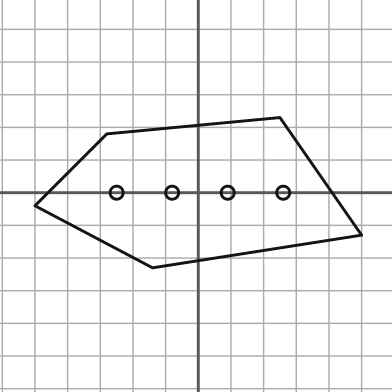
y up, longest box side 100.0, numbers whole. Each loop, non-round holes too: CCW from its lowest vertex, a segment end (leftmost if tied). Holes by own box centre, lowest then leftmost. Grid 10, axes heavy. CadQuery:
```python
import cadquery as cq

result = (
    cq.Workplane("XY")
    .moveTo(-14.0, -23.0)
    .lineTo(50.0, -13.0)
    .lineTo(25.0, 23.0)
    .lineTo(-28.0, 18.0)
    .lineTo(-50.0, -4.0)
    .close()
    .moveTo(-25.0, 0.0)
    .circle(2.0)
    .moveTo(-8.0, 0.0)
    .circle(2.0)
    .moveTo(9.0, 0.0)
    .circle(2.0)
    .moveTo(26.0, 0.0)
    .circle(2.0)
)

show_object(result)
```